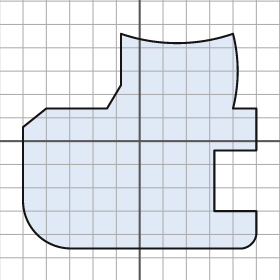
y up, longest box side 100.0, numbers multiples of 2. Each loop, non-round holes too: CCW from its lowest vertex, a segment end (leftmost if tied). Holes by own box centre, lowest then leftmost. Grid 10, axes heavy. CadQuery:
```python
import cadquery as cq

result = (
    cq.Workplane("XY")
    .moveTo(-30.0, -46.0)
    .lineTo(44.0, -46.0)
    .threePointArc((48.0, -44.0), (50.0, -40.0))
    .lineTo(50.0, -30.0)
    .lineTo(32.0, -30.0)
    .lineTo(32.0, -4.0)
    .lineTo(50.0, -4.0)
    .lineTo(50.0, 14.0)
    .lineTo(40.0, 14.0)
    .threePointArc((42.0, 30.0), (40.0, 46.0))
    .threePointArc((16.0, 42.0), (-8.0, 46.0))
    .lineTo(-8.0, 24.0)
    .lineTo(-14.0, 14.0)
    .lineTo(-40.0, 14.0)
    .lineTo(-50.0, 6.0)
    .lineTo(-50.0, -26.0)
    .threePointArc((-44.0, -40.0), (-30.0, -46.0))
    .close()
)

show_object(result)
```